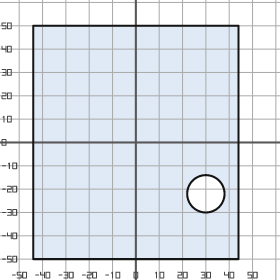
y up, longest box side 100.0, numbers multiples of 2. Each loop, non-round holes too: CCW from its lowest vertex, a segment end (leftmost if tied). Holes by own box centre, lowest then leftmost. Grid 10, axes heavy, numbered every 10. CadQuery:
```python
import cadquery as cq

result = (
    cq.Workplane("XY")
    .moveTo(-44.0, -50.0)
    .lineTo(44.0, -50.0)
    .lineTo(44.0, 50.0)
    .lineTo(-44.0, 50.0)
    .close()
    .moveTo(30.0, -22.0)
    .circle(8.0)
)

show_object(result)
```